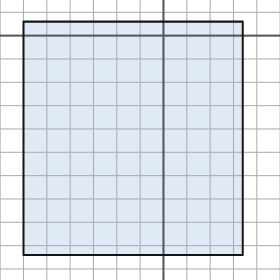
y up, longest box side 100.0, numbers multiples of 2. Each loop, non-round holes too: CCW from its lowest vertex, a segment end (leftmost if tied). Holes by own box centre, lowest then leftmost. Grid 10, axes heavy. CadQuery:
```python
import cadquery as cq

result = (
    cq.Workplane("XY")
    .moveTo(-60.0, -94.0)
    .lineTo(34.0, -94.0)
    .lineTo(34.0, 6.0)
    .lineTo(-60.0, 6.0)
    .close()
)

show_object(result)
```